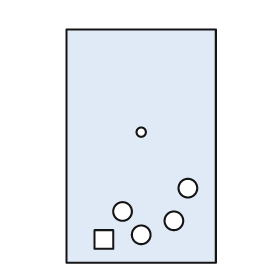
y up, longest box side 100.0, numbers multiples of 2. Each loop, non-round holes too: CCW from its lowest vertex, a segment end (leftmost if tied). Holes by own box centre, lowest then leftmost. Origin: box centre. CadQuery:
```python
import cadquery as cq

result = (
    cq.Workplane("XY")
    .moveTo(-32.0, -50.0)
    .lineTo(32.0, -50.0)
    .lineTo(32.0, 50.0)
    .lineTo(-32.0, 50.0)
    .close()
    .moveTo(-20.0, -44.0)
    .lineTo(-12.0, -44.0)
    .lineTo(-12.0, -36.0)
    .lineTo(-20.0, -36.0)
    .close()
    .moveTo(0.0, -38.0)
    .circle(4.0)
    .moveTo(14.0, -32.0)
    .circle(4.0)
    .moveTo(-8.0, -28.0)
    .circle(4.0)
    .moveTo(20.0, -18.0)
    .circle(4.0)
    .moveTo(0.0, 6.0)
    .circle(2.0)
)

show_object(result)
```